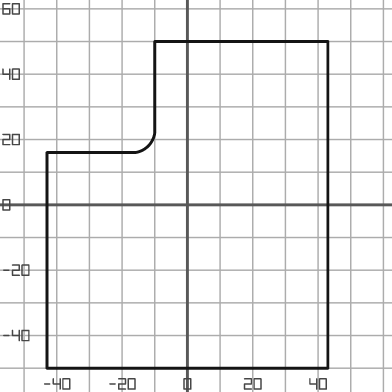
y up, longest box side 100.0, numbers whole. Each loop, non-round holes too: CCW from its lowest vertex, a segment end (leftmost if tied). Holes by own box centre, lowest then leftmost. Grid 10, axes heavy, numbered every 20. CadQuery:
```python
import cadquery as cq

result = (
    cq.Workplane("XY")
    .moveTo(-43.0, -50.0)
    .lineTo(43.0, -50.0)
    .lineTo(43.0, 50.0)
    .lineTo(-10.0, 50.0)
    .lineTo(-10.0, 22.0)
    .threePointArc((-12.0, 18.0), (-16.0, 16.0))
    .lineTo(-43.0, 16.0)
    .close()
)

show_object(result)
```